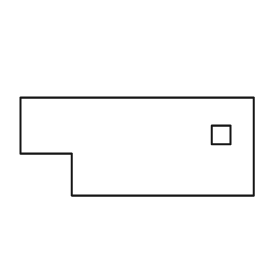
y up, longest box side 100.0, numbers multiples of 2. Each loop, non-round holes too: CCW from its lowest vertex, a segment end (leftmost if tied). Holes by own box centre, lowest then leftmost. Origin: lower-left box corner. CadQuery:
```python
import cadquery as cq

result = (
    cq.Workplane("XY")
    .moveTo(22.0, 0.0)
    .lineTo(100.0, 0.0)
    .lineTo(100.0, 42.0)
    .lineTo(0.0, 42.0)
    .lineTo(0.0, 18.0)
    .lineTo(22.0, 18.0)
    .close()
    .moveTo(82.0, 22.0)
    .lineTo(90.0, 22.0)
    .lineTo(90.0, 30.0)
    .lineTo(82.0, 30.0)
    .close()
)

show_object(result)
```